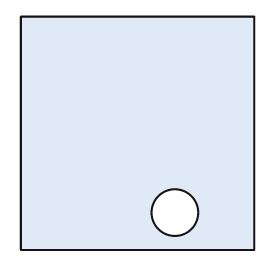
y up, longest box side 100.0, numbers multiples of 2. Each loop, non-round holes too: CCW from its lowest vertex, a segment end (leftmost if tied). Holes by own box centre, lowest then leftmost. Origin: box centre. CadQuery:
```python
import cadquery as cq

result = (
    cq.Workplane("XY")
    .moveTo(-50.0, -50.0)
    .lineTo(50.0, -50.0)
    .lineTo(50.0, 50.0)
    .lineTo(-50.0, 50.0)
    .close()
    .moveTo(16.0, -34.0)
    .circle(10.0)
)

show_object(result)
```